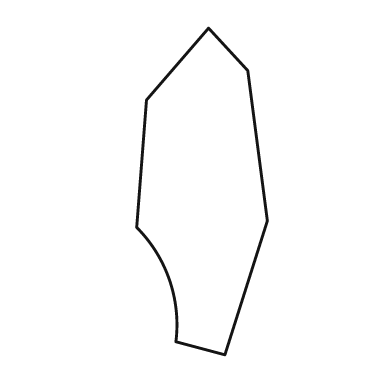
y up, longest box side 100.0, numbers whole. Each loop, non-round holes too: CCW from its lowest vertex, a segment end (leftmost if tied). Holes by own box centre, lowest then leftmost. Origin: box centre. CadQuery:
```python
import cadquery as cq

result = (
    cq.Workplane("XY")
    .moveTo(7.0, -50.0)
    .lineTo(20.0, -9.0)
    .lineTo(14.0, 37.0)
    .lineTo(2.0, 50.0)
    .lineTo(-17.0, 28.0)
    .lineTo(-20.0, -11.0)
    .threePointArc((-10.0, -27.0), (-8.0, -46.0))
    .close()
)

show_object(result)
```